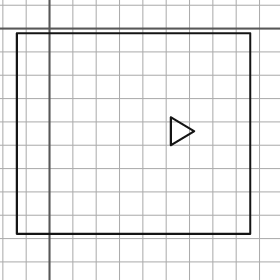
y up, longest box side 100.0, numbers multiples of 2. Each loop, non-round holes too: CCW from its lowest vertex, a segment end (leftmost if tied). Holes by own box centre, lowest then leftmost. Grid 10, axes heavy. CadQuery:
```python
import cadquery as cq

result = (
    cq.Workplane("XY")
    .moveTo(-14.0, -88.0)
    .lineTo(86.0, -88.0)
    .lineTo(86.0, -2.0)
    .lineTo(-14.0, -2.0)
    .close()
    .moveTo(52.0, -50.0)
    .lineTo(62.0, -44.0)
    .lineTo(52.0, -38.0)
    .close()
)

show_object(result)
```